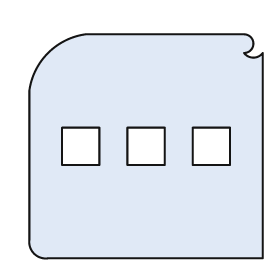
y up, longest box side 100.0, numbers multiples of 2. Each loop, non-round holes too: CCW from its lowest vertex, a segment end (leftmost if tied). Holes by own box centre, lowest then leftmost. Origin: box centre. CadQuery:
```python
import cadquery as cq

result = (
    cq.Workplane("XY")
    .moveTo(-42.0, -48.0)
    .lineTo(50.0, -48.0)
    .lineTo(50.0, 40.0)
    .threePointArc((46.0, 38.0), (42.0, 40.0))
    .threePointArc((46.0, 44.0), (42.0, 48.0))
    .lineTo(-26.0, 48.0)
    .threePointArc((-42.0, 40.0), (-50.0, 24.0))
    .lineTo(-50.0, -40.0)
    .threePointArc((-48.0, -46.0), (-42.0, -48.0))
    .close()
    .moveTo(-36.0, -8.0)
    .lineTo(-20.0, -8.0)
    .lineTo(-20.0, 8.0)
    .lineTo(-36.0, 8.0)
    .close()
    .moveTo(-8.0, -8.0)
    .lineTo(8.0, -8.0)
    .lineTo(8.0, 8.0)
    .lineTo(-8.0, 8.0)
    .close()
    .moveTo(20.0, -8.0)
    .lineTo(36.0, -8.0)
    .lineTo(36.0, 8.0)
    .lineTo(20.0, 8.0)
    .close()
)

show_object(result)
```